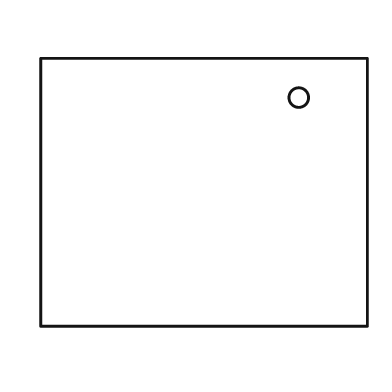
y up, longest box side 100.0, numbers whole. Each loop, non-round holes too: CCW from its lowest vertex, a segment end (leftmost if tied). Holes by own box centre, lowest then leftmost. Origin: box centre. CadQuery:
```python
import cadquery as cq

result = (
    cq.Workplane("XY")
    .moveTo(-50.0, -41.0)
    .lineTo(50.0, -41.0)
    .lineTo(50.0, 41.0)
    .lineTo(-50.0, 41.0)
    .close()
    .moveTo(29.0, 29.0)
    .circle(3.0)
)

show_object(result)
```